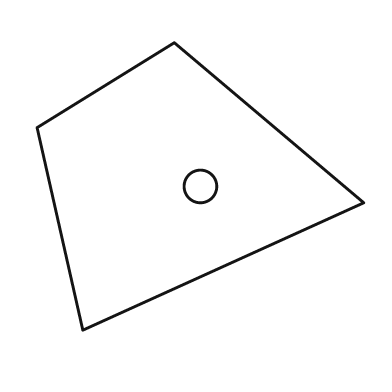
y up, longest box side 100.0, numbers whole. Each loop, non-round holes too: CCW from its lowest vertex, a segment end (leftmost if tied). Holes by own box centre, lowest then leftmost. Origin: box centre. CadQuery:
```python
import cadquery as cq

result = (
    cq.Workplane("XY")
    .moveTo(-36.0, -44.0)
    .lineTo(50.0, -5.0)
    .lineTo(-8.0, 44.0)
    .lineTo(-50.0, 18.0)
    .close()
    .moveTo(0.0, 0.0)
    .circle(5.0)
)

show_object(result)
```